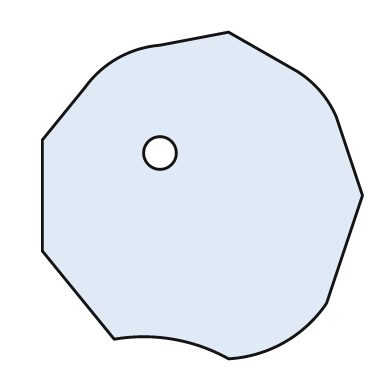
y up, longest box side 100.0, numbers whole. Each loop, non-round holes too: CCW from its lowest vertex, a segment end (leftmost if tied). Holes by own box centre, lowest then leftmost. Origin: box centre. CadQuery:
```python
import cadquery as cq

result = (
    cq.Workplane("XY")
    .moveTo(8.0, -50.0)
    .threePointArc((25.0, -45.0), (38.0, -33.0))
    .lineTo(49.0, 0.0)
    .lineTo(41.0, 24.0)
    .threePointArc((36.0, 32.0), (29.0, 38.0))
    .lineTo(8.0, 50.0)
    .lineTo(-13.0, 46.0)
    .threePointArc((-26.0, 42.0), (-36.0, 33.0))
    .lineTo(-49.0, 17.0)
    .lineTo(-49.0, -17.0)
    .lineTo(-27.0, -44.0)
    .threePointArc((-9.0, -44.0), (8.0, -50.0))
    .close()
    .moveTo(-13.0, 13.0)
    .circle(5.0)
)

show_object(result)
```